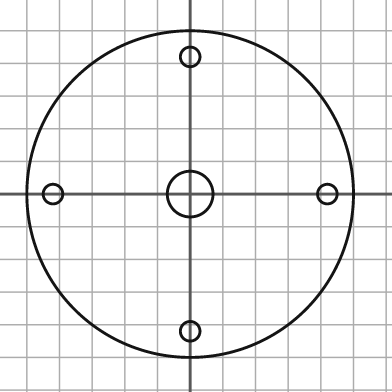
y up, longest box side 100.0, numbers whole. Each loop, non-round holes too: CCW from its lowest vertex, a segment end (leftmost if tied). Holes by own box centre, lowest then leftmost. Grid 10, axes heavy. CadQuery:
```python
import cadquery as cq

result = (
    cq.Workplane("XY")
    .moveTo(0.0, 0.0)
    .circle(50.0)
    .moveTo(0.0, -42.0)
    .circle(3.0)
    .moveTo(-42.0, 0.0)
    .circle(3.0)
    .moveTo(0.0, 0.0)
    .circle(7.0)
    .moveTo(42.0, 0.0)
    .circle(3.0)
    .moveTo(0.0, 42.0)
    .circle(3.0)
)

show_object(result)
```